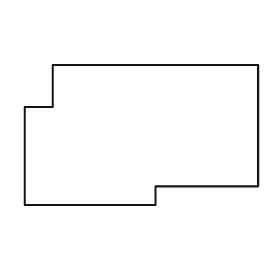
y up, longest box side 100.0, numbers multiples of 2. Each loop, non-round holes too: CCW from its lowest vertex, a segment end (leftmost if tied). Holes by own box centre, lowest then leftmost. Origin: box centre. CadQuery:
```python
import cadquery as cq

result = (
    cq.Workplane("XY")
    .moveTo(-50.0, -30.0)
    .lineTo(6.0, -30.0)
    .lineTo(6.0, -22.0)
    .lineTo(50.0, -22.0)
    .lineTo(50.0, 30.0)
    .lineTo(-38.0, 30.0)
    .lineTo(-38.0, 12.0)
    .lineTo(-50.0, 12.0)
    .close()
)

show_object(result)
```